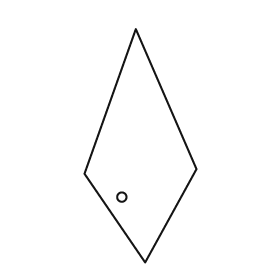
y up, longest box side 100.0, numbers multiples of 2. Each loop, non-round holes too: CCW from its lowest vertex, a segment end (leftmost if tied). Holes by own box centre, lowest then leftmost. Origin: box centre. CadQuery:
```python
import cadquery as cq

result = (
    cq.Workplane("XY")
    .moveTo(2.0, -50.0)
    .lineTo(24.0, -10.0)
    .lineTo(-2.0, 50.0)
    .lineTo(-24.0, -12.0)
    .close()
    .moveTo(-8.0, -22.0)
    .circle(2.0)
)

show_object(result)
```